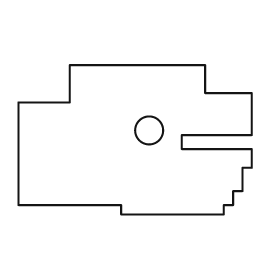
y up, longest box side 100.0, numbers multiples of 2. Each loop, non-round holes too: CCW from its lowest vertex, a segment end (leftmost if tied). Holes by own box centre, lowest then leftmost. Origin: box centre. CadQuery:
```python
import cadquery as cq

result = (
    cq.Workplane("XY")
    .moveTo(-6.0, -32.0)
    .lineTo(38.0, -32.0)
    .lineTo(38.0, -28.0)
    .lineTo(42.0, -28.0)
    .lineTo(42.0, -22.0)
    .lineTo(46.0, -22.0)
    .lineTo(46.0, -12.0)
    .lineTo(50.0, -12.0)
    .lineTo(50.0, -4.0)
    .lineTo(20.0, -4.0)
    .lineTo(20.0, 2.0)
    .lineTo(50.0, 2.0)
    .lineTo(50.0, 20.0)
    .lineTo(30.0, 20.0)
    .lineTo(30.0, 32.0)
    .lineTo(-28.0, 32.0)
    .lineTo(-28.0, 16.0)
    .lineTo(-50.0, 16.0)
    .lineTo(-50.0, -28.0)
    .lineTo(-6.0, -28.0)
    .close()
    .moveTo(6.0, 4.0)
    .circle(6.0)
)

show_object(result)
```